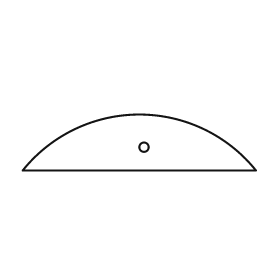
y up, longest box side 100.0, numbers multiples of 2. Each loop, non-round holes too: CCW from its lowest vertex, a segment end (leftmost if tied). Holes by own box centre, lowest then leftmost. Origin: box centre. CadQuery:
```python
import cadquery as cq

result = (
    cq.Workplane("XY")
    .moveTo(-50.0, -12.0)
    .lineTo(50.0, -12.0)
    .threePointArc((0.0, 12.0), (-50.0, -12.0))
    .close()
    .moveTo(2.0, -2.0)
    .circle(2.0)
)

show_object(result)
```